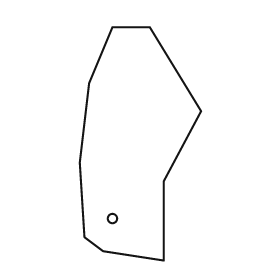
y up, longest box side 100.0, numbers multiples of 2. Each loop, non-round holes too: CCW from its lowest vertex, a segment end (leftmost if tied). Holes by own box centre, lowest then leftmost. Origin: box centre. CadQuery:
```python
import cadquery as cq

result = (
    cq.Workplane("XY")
    .moveTo(10.0, -50.0)
    .lineTo(10.0, -16.0)
    .lineTo(26.0, 14.0)
    .lineTo(4.0, 50.0)
    .lineTo(-12.0, 50.0)
    .lineTo(-22.0, 26.0)
    .lineTo(-26.0, -8.0)
    .lineTo(-24.0, -40.0)
    .lineTo(-16.0, -46.0)
    .close()
    .moveTo(-12.0, -32.0)
    .circle(2.0)
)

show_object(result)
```